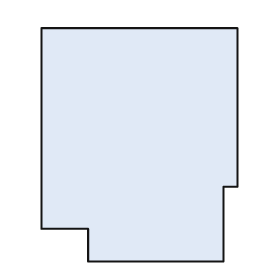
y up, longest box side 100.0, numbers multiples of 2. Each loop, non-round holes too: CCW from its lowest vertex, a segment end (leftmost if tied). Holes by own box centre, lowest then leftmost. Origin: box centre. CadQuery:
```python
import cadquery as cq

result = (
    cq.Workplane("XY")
    .moveTo(-22.0, -50.0)
    .lineTo(36.0, -50.0)
    .lineTo(36.0, -18.0)
    .lineTo(42.0, -18.0)
    .lineTo(42.0, 50.0)
    .lineTo(-42.0, 50.0)
    .lineTo(-42.0, -36.0)
    .lineTo(-22.0, -36.0)
    .close()
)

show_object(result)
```